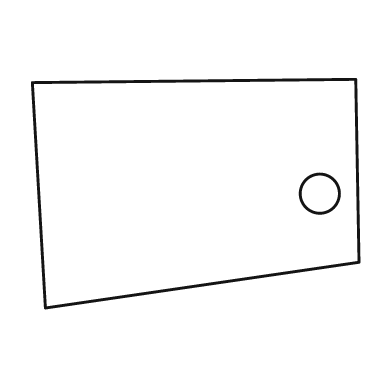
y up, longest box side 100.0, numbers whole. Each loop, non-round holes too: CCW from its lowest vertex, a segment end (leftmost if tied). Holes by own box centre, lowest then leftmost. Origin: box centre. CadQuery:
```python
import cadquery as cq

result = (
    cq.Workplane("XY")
    .moveTo(-46.0, -35.0)
    .lineTo(50.0, -21.0)
    .lineTo(49.0, 35.0)
    .lineTo(-50.0, 34.0)
    .close()
    .moveTo(38.0, 0.0)
    .circle(6.0)
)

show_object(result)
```